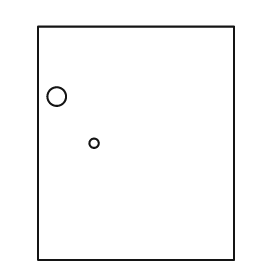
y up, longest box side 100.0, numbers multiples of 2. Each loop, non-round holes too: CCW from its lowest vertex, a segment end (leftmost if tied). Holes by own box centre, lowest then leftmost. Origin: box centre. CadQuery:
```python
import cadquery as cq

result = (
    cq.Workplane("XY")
    .moveTo(-42.0, -50.0)
    .lineTo(42.0, -50.0)
    .lineTo(42.0, 50.0)
    .lineTo(-42.0, 50.0)
    .close()
    .moveTo(-18.0, 0.0)
    .circle(2.0)
    .moveTo(-34.0, 20.0)
    .circle(4.0)
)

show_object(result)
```